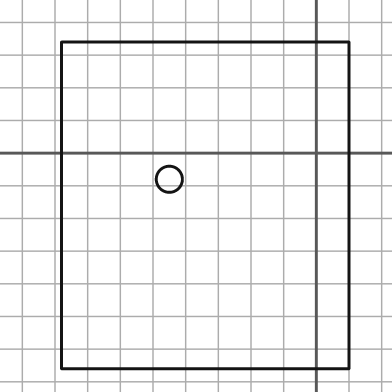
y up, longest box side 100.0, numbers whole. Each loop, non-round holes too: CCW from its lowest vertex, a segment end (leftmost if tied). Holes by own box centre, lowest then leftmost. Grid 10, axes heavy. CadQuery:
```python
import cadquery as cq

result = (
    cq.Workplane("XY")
    .moveTo(-78.0, -66.0)
    .lineTo(10.0, -66.0)
    .lineTo(10.0, 34.0)
    .lineTo(-78.0, 34.0)
    .close()
    .moveTo(-45.0, -8.0)
    .circle(4.0)
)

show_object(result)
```